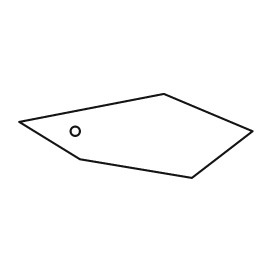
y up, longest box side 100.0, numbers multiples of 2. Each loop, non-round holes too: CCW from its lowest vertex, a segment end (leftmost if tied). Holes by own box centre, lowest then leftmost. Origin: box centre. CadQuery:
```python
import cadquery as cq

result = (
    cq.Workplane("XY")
    .moveTo(24.0, -18.0)
    .lineTo(50.0, 2.0)
    .lineTo(12.0, 18.0)
    .lineTo(-50.0, 6.0)
    .lineTo(-24.0, -10.0)
    .close()
    .moveTo(-26.0, 2.0)
    .circle(2.0)
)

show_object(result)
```